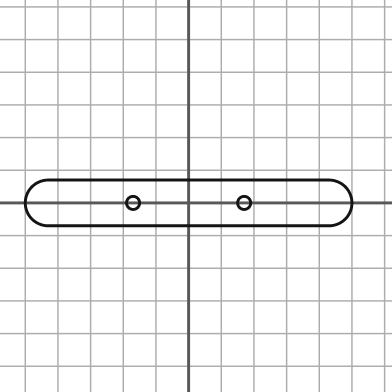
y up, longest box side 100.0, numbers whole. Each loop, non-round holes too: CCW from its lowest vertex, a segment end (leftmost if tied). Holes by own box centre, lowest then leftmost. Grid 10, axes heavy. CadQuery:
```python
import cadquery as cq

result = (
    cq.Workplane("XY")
    .moveTo(-43.0, -7.0)
    .lineTo(43.0, -7.0)
    .threePointArc((50.0, 0.0), (43.0, 7.0))
    .lineTo(-43.0, 7.0)
    .threePointArc((-50.0, 0.0), (-43.0, -7.0))
    .close()
    .moveTo(-17.0, 0.0)
    .circle(2.0)
    .moveTo(17.0, 0.0)
    .circle(2.0)
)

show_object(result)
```